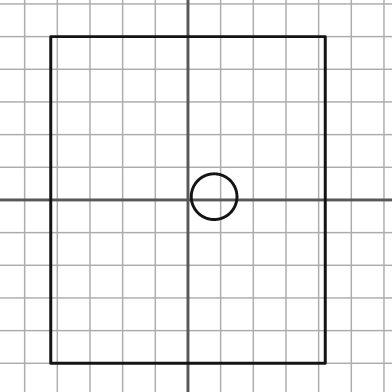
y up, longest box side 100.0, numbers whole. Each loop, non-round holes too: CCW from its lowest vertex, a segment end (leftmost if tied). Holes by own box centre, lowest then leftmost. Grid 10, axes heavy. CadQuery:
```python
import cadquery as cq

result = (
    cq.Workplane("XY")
    .moveTo(-42.0, -50.0)
    .lineTo(42.0, -50.0)
    .lineTo(42.0, 50.0)
    .lineTo(-42.0, 50.0)
    .close()
    .moveTo(8.0, 1.0)
    .circle(7.0)
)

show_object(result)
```